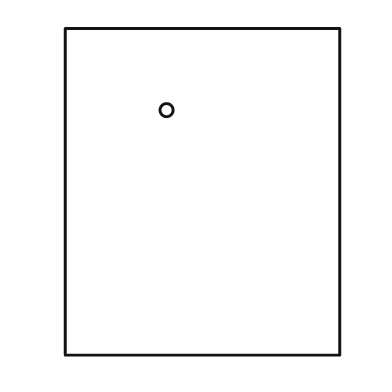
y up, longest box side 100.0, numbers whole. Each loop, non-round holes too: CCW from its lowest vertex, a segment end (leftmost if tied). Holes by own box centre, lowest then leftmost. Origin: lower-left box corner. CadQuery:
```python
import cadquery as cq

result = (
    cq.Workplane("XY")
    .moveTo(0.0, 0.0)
    .lineTo(84.0, 0.0)
    .lineTo(84.0, 100.0)
    .lineTo(0.0, 100.0)
    .close()
    .moveTo(31.0, 75.0)
    .circle(2.0)
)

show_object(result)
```